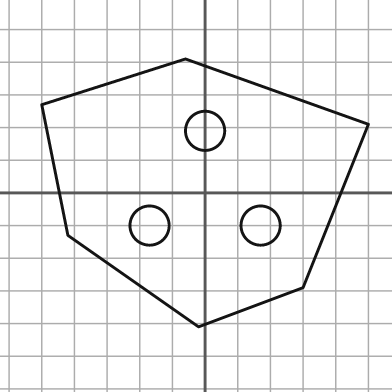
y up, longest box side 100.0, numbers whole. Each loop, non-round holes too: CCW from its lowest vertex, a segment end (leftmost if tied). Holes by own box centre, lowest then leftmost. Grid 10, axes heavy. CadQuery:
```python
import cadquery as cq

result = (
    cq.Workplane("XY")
    .moveTo(-2.0, -41.0)
    .lineTo(30.0, -29.0)
    .lineTo(50.0, 21.0)
    .lineTo(-6.0, 41.0)
    .lineTo(-50.0, 27.0)
    .lineTo(-42.0, -13.0)
    .close()
    .moveTo(-17.0, -10.0)
    .circle(6.0)
    .moveTo(17.0, -10.0)
    .circle(6.0)
    .moveTo(0.0, 19.0)
    .circle(6.0)
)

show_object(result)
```